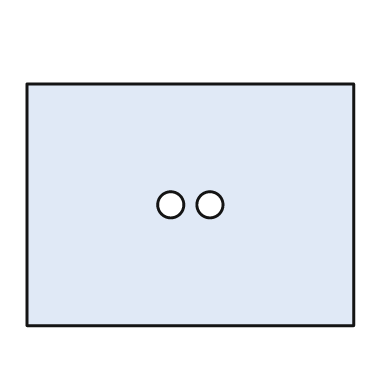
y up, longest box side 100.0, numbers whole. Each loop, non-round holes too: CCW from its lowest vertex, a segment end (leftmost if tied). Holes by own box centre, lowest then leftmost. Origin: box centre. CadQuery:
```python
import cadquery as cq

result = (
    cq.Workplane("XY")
    .moveTo(-50.0, -37.0)
    .lineTo(50.0, -37.0)
    .lineTo(50.0, 37.0)
    .lineTo(-50.0, 37.0)
    .close()
    .moveTo(-6.0, 0.0)
    .circle(4.0)
    .moveTo(6.0, 0.0)
    .circle(4.0)
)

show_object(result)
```